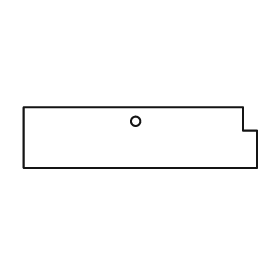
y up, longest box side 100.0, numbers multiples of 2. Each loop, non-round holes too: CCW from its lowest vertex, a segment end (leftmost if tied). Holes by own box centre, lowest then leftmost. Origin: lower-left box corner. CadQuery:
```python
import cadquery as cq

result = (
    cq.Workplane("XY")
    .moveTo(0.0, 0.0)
    .lineTo(100.0, 0.0)
    .lineTo(100.0, 16.0)
    .lineTo(94.0, 16.0)
    .lineTo(94.0, 26.0)
    .lineTo(0.0, 26.0)
    .close()
    .moveTo(48.0, 20.0)
    .circle(2.0)
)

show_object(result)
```